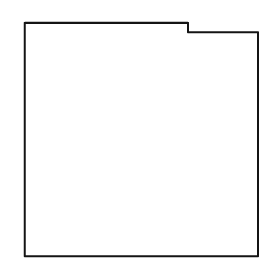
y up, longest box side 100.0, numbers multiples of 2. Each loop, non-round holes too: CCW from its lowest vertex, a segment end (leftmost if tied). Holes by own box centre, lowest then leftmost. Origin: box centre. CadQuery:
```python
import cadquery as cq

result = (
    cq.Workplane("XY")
    .moveTo(-50.0, -50.0)
    .lineTo(50.0, -50.0)
    .lineTo(50.0, 46.0)
    .lineTo(20.0, 46.0)
    .lineTo(20.0, 50.0)
    .lineTo(-50.0, 50.0)
    .close()
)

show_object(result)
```